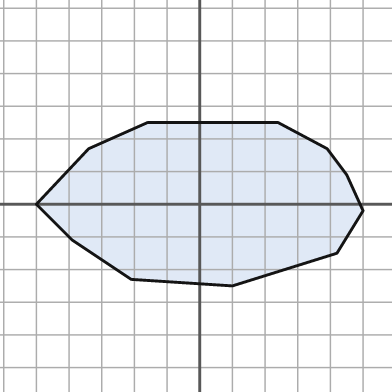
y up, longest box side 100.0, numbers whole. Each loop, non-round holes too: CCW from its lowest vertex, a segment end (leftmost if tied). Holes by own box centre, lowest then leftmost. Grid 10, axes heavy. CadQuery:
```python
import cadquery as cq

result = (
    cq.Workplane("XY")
    .moveTo(10.0, -25.0)
    .lineTo(42.0, -15.0)
    .lineTo(50.0, -2.0)
    .lineTo(45.0, 9.0)
    .lineTo(39.0, 17.0)
    .lineTo(24.0, 25.0)
    .lineTo(-16.0, 25.0)
    .lineTo(-34.0, 17.0)
    .lineTo(-50.0, 0.0)
    .lineTo(-39.0, -11.0)
    .lineTo(-21.0, -23.0)
    .close()
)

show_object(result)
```